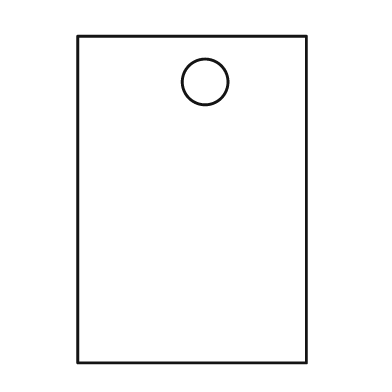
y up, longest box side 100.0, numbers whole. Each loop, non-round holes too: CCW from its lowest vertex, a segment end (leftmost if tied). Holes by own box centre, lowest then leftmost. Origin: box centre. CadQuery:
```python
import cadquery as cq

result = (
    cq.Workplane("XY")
    .moveTo(-35.0, -50.0)
    .lineTo(35.0, -50.0)
    .lineTo(35.0, 50.0)
    .lineTo(-35.0, 50.0)
    .close()
    .moveTo(4.0, 36.0)
    .circle(7.0)
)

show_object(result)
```